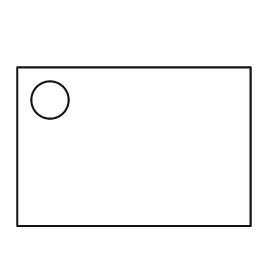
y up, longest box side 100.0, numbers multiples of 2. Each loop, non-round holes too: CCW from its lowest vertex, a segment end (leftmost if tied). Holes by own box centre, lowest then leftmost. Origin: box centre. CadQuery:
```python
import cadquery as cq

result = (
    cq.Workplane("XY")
    .moveTo(-50.0, -34.0)
    .lineTo(50.0, -34.0)
    .lineTo(50.0, 34.0)
    .lineTo(-50.0, 34.0)
    .close()
    .moveTo(-36.0, 20.0)
    .circle(8.0)
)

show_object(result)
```